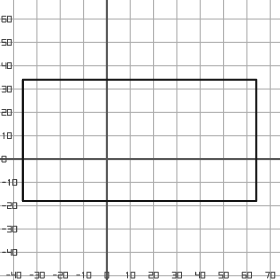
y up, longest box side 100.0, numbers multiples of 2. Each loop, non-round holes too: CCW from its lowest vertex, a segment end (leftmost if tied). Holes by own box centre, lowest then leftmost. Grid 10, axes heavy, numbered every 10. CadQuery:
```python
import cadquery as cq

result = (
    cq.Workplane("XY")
    .moveTo(-36.0, -18.0)
    .lineTo(64.0, -18.0)
    .lineTo(64.0, 34.0)
    .lineTo(-36.0, 34.0)
    .close()
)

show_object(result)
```